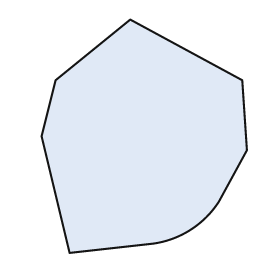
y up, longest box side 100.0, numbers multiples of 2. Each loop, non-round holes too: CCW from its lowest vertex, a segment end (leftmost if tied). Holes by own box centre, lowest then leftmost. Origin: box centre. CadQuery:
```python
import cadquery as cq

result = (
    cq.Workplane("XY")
    .moveTo(-32.0, -50.0)
    .lineTo(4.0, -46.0)
    .threePointArc((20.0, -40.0), (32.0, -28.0))
    .lineTo(44.0, -6.0)
    .lineTo(42.0, 24.0)
    .lineTo(-6.0, 50.0)
    .lineTo(-38.0, 24.0)
    .lineTo(-44.0, 0.0)
    .close()
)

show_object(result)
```